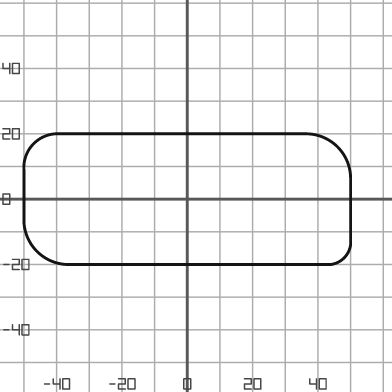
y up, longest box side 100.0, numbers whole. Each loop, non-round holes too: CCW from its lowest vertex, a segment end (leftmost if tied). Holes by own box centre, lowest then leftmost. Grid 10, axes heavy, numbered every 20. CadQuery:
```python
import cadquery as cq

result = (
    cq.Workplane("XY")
    .moveTo(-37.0, -20.0)
    .lineTo(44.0, -20.0)
    .threePointArc((48.0, -18.0), (50.0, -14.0))
    .lineTo(50.0, 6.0)
    .threePointArc((46.0, 16.0), (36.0, 20.0))
    .lineTo(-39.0, 20.0)
    .threePointArc((-47.0, 17.0), (-50.0, 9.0))
    .lineTo(-50.0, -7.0)
    .threePointArc((-46.0, -16.0), (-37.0, -20.0))
    .close()
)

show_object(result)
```